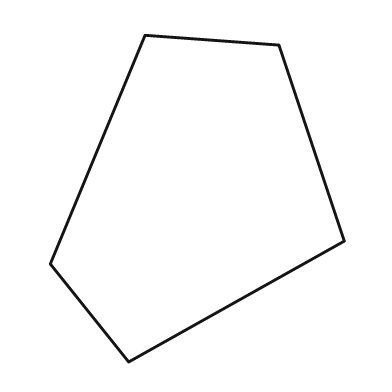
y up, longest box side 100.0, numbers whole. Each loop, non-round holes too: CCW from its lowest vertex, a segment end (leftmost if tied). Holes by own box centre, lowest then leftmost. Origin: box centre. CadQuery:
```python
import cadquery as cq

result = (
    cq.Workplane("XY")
    .moveTo(-21.0, -50.0)
    .lineTo(45.0, -13.0)
    .lineTo(25.0, 47.0)
    .lineTo(-16.0, 50.0)
    .lineTo(-45.0, -20.0)
    .close()
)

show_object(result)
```